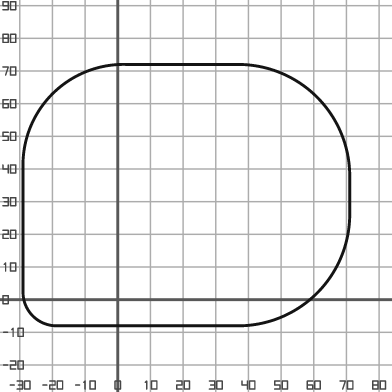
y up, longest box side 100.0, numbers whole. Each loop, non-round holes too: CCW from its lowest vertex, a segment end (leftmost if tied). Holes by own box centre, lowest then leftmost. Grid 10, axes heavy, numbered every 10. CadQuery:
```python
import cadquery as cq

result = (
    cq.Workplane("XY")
    .moveTo(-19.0, -8.0)
    .lineTo(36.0, -8.0)
    .threePointArc((61.0, 2.0), (71.0, 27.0))
    .lineTo(71.0, 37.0)
    .threePointArc((61.0, 62.0), (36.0, 72.0))
    .lineTo(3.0, 72.0)
    .threePointArc((-20.0, 63.0), (-29.0, 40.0))
    .lineTo(-29.0, 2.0)
    .threePointArc((-26.0, -5.0), (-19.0, -8.0))
    .close()
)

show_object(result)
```